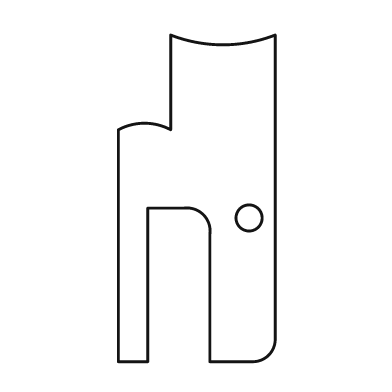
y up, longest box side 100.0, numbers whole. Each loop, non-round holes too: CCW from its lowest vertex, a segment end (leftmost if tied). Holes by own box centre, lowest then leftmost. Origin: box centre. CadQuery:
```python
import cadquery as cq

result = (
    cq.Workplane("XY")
    .moveTo(-24.0, -50.0)
    .lineTo(-15.0, -50.0)
    .lineTo(-15.0, -3.0)
    .lineTo(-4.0, -3.0)
    .threePointArc((2.0, -5.0), (4.0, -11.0))
    .lineTo(4.0, -50.0)
    .lineTo(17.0, -50.0)
    .threePointArc((22.0, -48.0), (24.0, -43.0))
    .lineTo(24.0, 50.0)
    .threePointArc((8.0, 47.0), (-8.0, 50.0))
    .lineTo(-8.0, 21.0)
    .threePointArc((-16.0, 23.0), (-24.0, 21.0))
    .close()
    .moveTo(16.0, -6.0)
    .circle(4.0)
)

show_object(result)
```